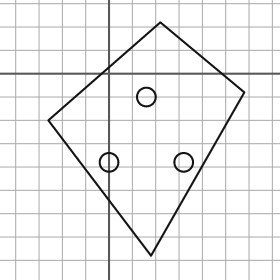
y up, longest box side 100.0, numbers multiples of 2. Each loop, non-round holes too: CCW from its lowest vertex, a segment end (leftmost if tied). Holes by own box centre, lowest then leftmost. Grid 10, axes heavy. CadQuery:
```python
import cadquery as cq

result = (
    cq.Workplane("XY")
    .moveTo(18.0, -78.0)
    .lineTo(58.0, -8.0)
    .lineTo(22.0, 22.0)
    .lineTo(-26.0, -20.0)
    .close()
    .moveTo(0.0, -38.0)
    .circle(4.0)
    .moveTo(32.0, -38.0)
    .circle(4.0)
    .moveTo(16.0, -10.0)
    .circle(4.0)
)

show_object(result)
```